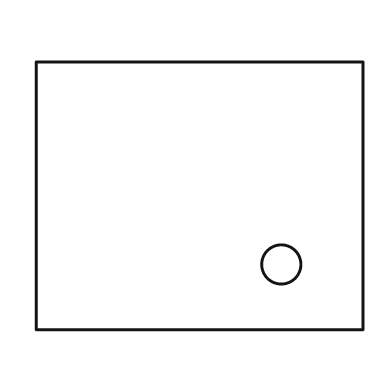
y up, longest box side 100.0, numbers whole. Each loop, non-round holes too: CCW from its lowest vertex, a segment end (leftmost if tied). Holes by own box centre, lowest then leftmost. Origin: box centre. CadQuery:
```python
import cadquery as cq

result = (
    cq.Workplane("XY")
    .moveTo(-50.0, -41.0)
    .lineTo(50.0, -41.0)
    .lineTo(50.0, 41.0)
    .lineTo(-50.0, 41.0)
    .close()
    .moveTo(25.0, -21.0)
    .circle(6.0)
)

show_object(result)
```